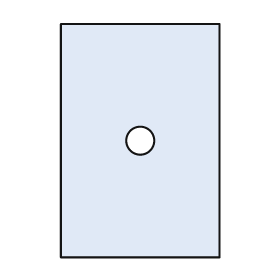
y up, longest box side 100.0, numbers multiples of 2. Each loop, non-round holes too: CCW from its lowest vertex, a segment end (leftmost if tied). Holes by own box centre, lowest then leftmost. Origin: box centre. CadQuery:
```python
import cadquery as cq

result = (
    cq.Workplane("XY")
    .moveTo(-34.0, -50.0)
    .lineTo(34.0, -50.0)
    .lineTo(34.0, 50.0)
    .lineTo(-34.0, 50.0)
    .close()
    .moveTo(0.0, 0.0)
    .circle(6.0)
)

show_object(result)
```